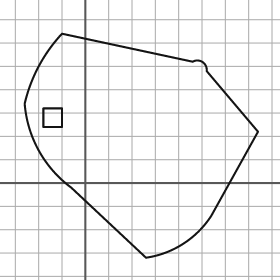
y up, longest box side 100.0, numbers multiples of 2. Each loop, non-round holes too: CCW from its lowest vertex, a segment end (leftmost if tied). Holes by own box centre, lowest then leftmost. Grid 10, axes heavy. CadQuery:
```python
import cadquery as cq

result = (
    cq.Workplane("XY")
    .moveTo(26.0, -32.0)
    .threePointArc((42.0, -26.0), (54.0, -14.0))
    .lineTo(74.0, 22.0)
    .lineTo(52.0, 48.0)
    .threePointArc((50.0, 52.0), (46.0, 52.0))
    .lineTo(-10.0, 64.0)
    .threePointArc((-20.0, 50.0), (-26.0, 34.0))
    .threePointArc((-20.0, 14.0), (-6.0, -2.0))
    .close()
    .moveTo(-18.0, 24.0)
    .lineTo(-10.0, 24.0)
    .lineTo(-10.0, 32.0)
    .lineTo(-18.0, 32.0)
    .close()
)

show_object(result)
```